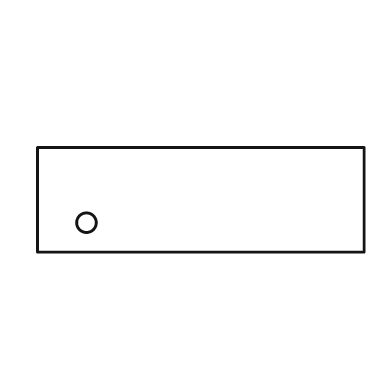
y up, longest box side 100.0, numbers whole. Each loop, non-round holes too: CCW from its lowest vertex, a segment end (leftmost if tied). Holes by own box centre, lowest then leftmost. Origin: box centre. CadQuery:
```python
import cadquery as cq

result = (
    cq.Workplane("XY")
    .moveTo(-50.0, -16.0)
    .lineTo(50.0, -16.0)
    .lineTo(50.0, 16.0)
    .lineTo(-50.0, 16.0)
    .close()
    .moveTo(-35.0, -7.0)
    .circle(3.0)
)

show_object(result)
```